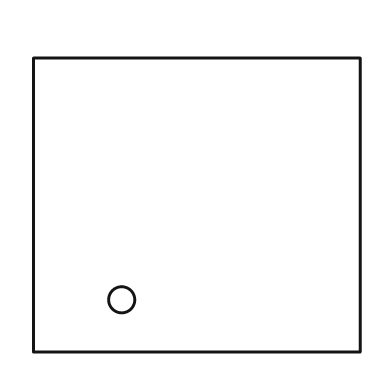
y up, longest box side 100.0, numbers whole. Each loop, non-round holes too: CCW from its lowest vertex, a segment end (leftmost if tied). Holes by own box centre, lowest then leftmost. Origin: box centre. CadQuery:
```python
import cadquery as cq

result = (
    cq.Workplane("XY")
    .moveTo(-50.0, -45.0)
    .lineTo(50.0, -45.0)
    .lineTo(50.0, 45.0)
    .lineTo(-50.0, 45.0)
    .close()
    .moveTo(-23.0, -29.0)
    .circle(4.0)
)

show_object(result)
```